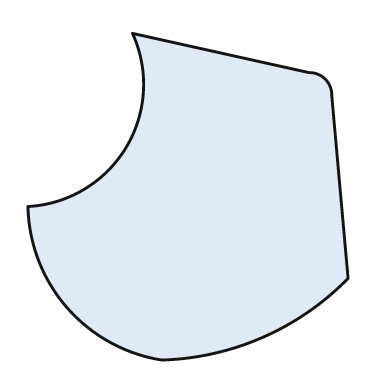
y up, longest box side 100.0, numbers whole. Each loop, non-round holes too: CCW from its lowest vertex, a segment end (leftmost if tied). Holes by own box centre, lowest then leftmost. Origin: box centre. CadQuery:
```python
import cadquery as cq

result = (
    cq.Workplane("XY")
    .moveTo(-8.0, -50.0)
    .threePointArc((23.0, -43.0), (49.0, -25.0))
    .lineTo(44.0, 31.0)
    .threePointArc((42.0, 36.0), (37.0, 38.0))
    .lineTo(-17.0, 50.0)
    .threePointArc((-19.0, 15.0), (-49.0, -3.0))
    .threePointArc((-37.0, -34.0), (-8.0, -50.0))
    .close()
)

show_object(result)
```